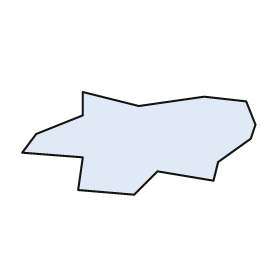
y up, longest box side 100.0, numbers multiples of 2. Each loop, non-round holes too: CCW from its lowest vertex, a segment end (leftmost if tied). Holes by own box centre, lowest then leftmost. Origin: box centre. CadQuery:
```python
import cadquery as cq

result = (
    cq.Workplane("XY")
    .moveTo(-2.0, -22.0)
    .lineTo(8.0, -12.0)
    .lineTo(32.0, -16.0)
    .lineTo(34.0, -8.0)
    .lineTo(48.0, 2.0)
    .lineTo(50.0, 8.0)
    .lineTo(46.0, 18.0)
    .lineTo(28.0, 20.0)
    .lineTo(0.0, 16.0)
    .lineTo(-24.0, 22.0)
    .lineTo(-24.0, 12.0)
    .lineTo(-44.0, 4.0)
    .lineTo(-50.0, -4.0)
    .lineTo(-24.0, -6.0)
    .lineTo(-26.0, -20.0)
    .close()
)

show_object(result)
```